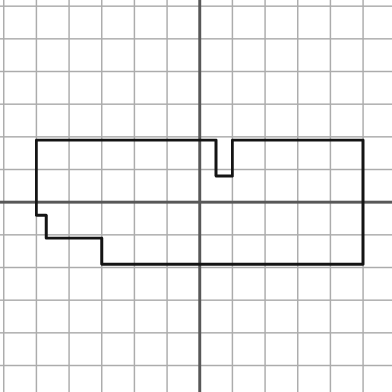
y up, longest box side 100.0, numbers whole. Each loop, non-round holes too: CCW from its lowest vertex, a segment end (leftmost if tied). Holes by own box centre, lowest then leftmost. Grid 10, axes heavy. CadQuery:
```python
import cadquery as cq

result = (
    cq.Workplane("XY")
    .moveTo(-30.0, -19.0)
    .lineTo(50.0, -19.0)
    .lineTo(50.0, 19.0)
    .lineTo(10.0, 19.0)
    .lineTo(10.0, 8.0)
    .lineTo(5.0, 8.0)
    .lineTo(5.0, 19.0)
    .lineTo(-50.0, 19.0)
    .lineTo(-50.0, -4.0)
    .lineTo(-47.0, -4.0)
    .lineTo(-47.0, -11.0)
    .lineTo(-30.0, -11.0)
    .close()
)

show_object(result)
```